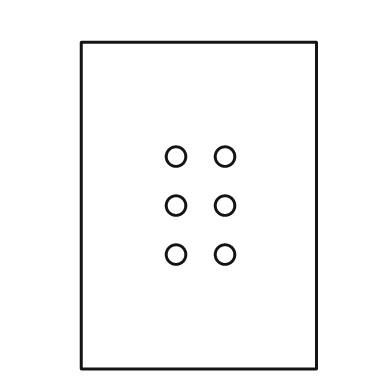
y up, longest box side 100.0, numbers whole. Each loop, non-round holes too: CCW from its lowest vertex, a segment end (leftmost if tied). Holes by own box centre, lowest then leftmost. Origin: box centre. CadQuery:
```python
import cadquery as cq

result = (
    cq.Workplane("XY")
    .moveTo(-36.0, -50.0)
    .lineTo(36.0, -50.0)
    .lineTo(36.0, 50.0)
    .lineTo(-36.0, 50.0)
    .close()
    .moveTo(-7.0, -15.0)
    .circle(3.0)
    .moveTo(8.0, -15.0)
    .circle(3.0)
    .moveTo(-7.0, 0.0)
    .circle(3.0)
    .moveTo(8.0, 0.0)
    .circle(3.0)
    .moveTo(-7.0, 15.0)
    .circle(3.0)
    .moveTo(8.0, 15.0)
    .circle(3.0)
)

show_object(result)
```